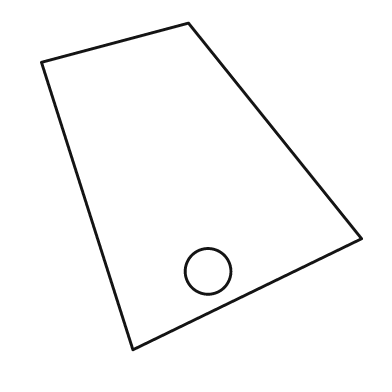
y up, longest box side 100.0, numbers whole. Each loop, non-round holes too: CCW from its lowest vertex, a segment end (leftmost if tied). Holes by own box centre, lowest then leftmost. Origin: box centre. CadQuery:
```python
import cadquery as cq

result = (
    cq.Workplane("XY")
    .moveTo(-21.0, -50.0)
    .lineTo(49.0, -16.0)
    .lineTo(-4.0, 50.0)
    .lineTo(-49.0, 38.0)
    .close()
    .moveTo(2.0, -26.0)
    .circle(7.0)
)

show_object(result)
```